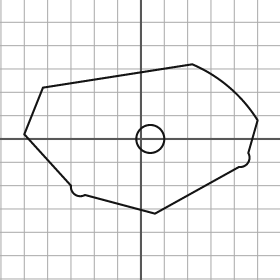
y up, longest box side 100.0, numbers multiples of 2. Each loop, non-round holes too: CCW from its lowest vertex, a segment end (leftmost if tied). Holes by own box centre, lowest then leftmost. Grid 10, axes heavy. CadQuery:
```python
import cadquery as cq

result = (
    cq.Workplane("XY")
    .moveTo(6.0, -32.0)
    .lineTo(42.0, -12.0)
    .threePointArc((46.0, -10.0), (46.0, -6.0))
    .lineTo(50.0, 8.0)
    .threePointArc((38.0, 22.0), (22.0, 32.0))
    .lineTo(-42.0, 22.0)
    .lineTo(-50.0, 2.0)
    .lineTo(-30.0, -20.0)
    .threePointArc((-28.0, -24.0), (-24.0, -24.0))
    .close()
    .moveTo(4.0, 0.0)
    .circle(6.0)
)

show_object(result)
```